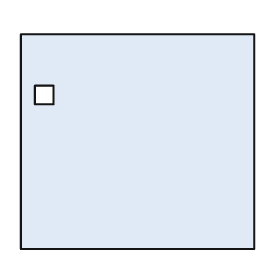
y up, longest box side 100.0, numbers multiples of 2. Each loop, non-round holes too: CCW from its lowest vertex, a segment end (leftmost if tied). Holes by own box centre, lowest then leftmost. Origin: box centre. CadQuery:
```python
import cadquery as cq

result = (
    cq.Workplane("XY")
    .moveTo(-50.0, -46.0)
    .lineTo(50.0, -46.0)
    .lineTo(50.0, 46.0)
    .lineTo(-50.0, 46.0)
    .close()
    .moveTo(-44.0, 16.0)
    .lineTo(-36.0, 16.0)
    .lineTo(-36.0, 24.0)
    .lineTo(-44.0, 24.0)
    .close()
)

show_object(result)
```